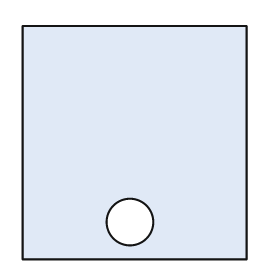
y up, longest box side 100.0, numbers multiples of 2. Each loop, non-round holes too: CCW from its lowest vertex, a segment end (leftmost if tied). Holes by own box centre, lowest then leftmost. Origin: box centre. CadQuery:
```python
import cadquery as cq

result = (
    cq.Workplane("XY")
    .moveTo(-48.0, -50.0)
    .lineTo(48.0, -50.0)
    .lineTo(48.0, 50.0)
    .lineTo(-48.0, 50.0)
    .close()
    .moveTo(-2.0, -34.0)
    .circle(10.0)
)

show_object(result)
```